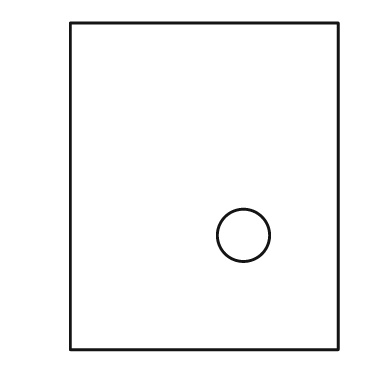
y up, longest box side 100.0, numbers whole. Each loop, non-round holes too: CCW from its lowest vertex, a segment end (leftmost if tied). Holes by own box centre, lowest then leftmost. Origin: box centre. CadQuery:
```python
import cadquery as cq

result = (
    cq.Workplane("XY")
    .moveTo(-41.0, -50.0)
    .lineTo(41.0, -50.0)
    .lineTo(41.0, 50.0)
    .lineTo(-41.0, 50.0)
    .close()
    .moveTo(12.0, -15.0)
    .circle(8.0)
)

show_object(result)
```